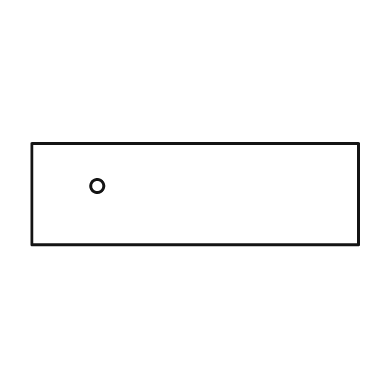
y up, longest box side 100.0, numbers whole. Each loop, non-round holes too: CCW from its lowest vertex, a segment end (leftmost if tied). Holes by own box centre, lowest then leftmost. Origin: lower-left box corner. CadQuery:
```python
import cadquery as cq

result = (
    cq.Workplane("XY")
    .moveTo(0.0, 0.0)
    .lineTo(100.0, 0.0)
    .lineTo(100.0, 31.0)
    .lineTo(0.0, 31.0)
    .close()
    .moveTo(20.0, 18.0)
    .circle(2.0)
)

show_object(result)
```